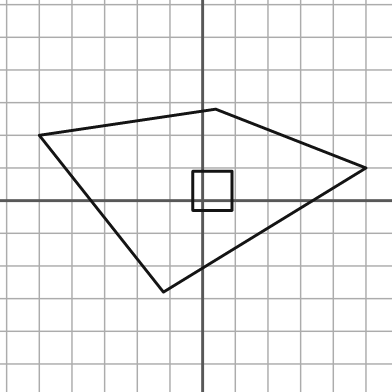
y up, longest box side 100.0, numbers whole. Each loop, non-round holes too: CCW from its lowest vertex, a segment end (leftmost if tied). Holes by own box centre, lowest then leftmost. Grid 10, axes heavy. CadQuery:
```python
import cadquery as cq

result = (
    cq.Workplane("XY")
    .moveTo(-12.0, -28.0)
    .lineTo(50.0, 10.0)
    .lineTo(4.0, 28.0)
    .lineTo(-50.0, 20.0)
    .close()
    .moveTo(-3.0, -3.0)
    .lineTo(9.0, -3.0)
    .lineTo(9.0, 9.0)
    .lineTo(-3.0, 9.0)
    .close()
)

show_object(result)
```